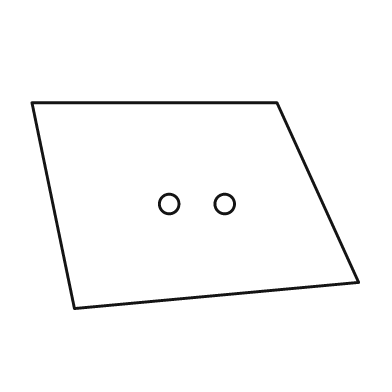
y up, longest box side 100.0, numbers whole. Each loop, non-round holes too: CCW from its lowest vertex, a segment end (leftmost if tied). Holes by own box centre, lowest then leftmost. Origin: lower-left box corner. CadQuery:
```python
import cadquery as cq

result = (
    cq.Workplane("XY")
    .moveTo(13.0, 0.0)
    .lineTo(100.0, 8.0)
    .lineTo(75.0, 63.0)
    .lineTo(0.0, 63.0)
    .close()
    .moveTo(42.0, 32.0)
    .circle(3.0)
    .moveTo(59.0, 32.0)
    .circle(3.0)
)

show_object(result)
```